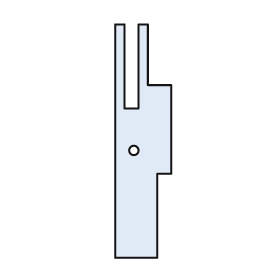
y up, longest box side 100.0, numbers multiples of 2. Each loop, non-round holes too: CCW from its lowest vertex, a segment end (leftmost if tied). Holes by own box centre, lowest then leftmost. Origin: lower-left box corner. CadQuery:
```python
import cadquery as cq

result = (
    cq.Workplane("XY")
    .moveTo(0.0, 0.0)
    .lineTo(18.0, 0.0)
    .lineTo(18.0, 36.0)
    .lineTo(24.0, 36.0)
    .lineTo(24.0, 74.0)
    .lineTo(14.0, 74.0)
    .lineTo(14.0, 100.0)
    .lineTo(10.0, 100.0)
    .lineTo(10.0, 64.0)
    .lineTo(4.0, 64.0)
    .lineTo(4.0, 100.0)
    .lineTo(0.0, 100.0)
    .close()
    .moveTo(8.0, 46.0)
    .circle(2.0)
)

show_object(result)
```